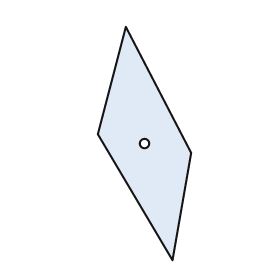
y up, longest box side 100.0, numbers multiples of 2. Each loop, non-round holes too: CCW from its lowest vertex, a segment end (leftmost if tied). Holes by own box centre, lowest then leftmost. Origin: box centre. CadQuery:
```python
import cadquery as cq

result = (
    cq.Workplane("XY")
    .moveTo(12.0, -50.0)
    .lineTo(20.0, -4.0)
    .lineTo(-8.0, 50.0)
    .lineTo(-20.0, 4.0)
    .close()
    .moveTo(0.0, 0.0)
    .circle(2.0)
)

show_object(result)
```